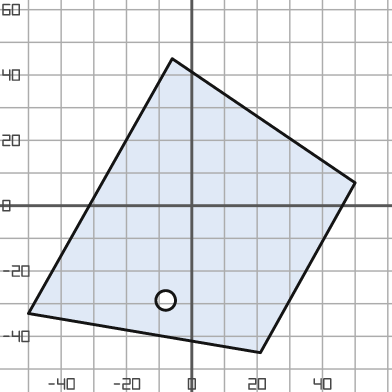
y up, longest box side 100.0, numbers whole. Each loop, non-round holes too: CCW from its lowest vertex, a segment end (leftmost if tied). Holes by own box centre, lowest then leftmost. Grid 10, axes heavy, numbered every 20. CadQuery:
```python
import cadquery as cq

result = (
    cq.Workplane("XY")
    .moveTo(21.0, -45.0)
    .lineTo(50.0, 7.0)
    .lineTo(-6.0, 45.0)
    .lineTo(-50.0, -33.0)
    .close()
    .moveTo(-8.0, -29.0)
    .circle(3.0)
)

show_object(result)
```